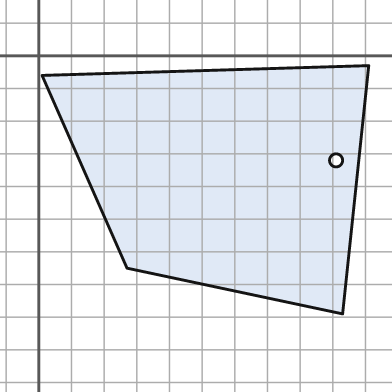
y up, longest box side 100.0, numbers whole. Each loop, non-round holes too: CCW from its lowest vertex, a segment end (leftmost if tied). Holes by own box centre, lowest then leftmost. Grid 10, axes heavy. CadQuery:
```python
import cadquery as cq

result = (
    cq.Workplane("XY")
    .moveTo(93.0, -79.0)
    .lineTo(101.0, -3.0)
    .lineTo(1.0, -6.0)
    .lineTo(27.0, -65.0)
    .close()
    .moveTo(91.0, -32.0)
    .circle(2.0)
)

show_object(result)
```